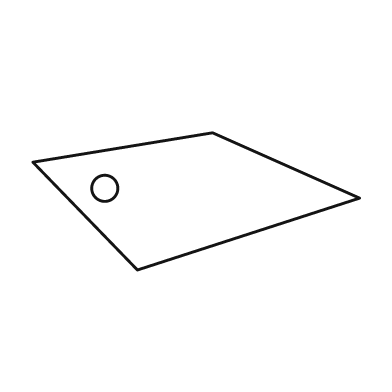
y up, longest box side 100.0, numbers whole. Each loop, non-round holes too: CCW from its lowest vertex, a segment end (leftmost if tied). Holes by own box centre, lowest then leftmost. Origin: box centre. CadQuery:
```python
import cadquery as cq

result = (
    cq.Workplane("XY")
    .moveTo(-18.0, -21.0)
    .lineTo(50.0, 1.0)
    .lineTo(5.0, 21.0)
    .lineTo(-50.0, 12.0)
    .close()
    .moveTo(-28.0, 4.0)
    .circle(4.0)
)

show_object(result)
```